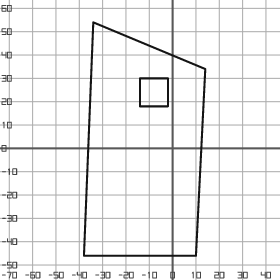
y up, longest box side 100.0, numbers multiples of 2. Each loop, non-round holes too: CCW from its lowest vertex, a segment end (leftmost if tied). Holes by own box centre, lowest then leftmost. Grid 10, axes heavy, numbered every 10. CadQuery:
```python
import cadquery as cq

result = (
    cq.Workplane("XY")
    .moveTo(-38.0, -46.0)
    .lineTo(10.0, -46.0)
    .lineTo(14.0, 34.0)
    .lineTo(-34.0, 54.0)
    .close()
    .moveTo(-14.0, 18.0)
    .lineTo(-2.0, 18.0)
    .lineTo(-2.0, 30.0)
    .lineTo(-14.0, 30.0)
    .close()
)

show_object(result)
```